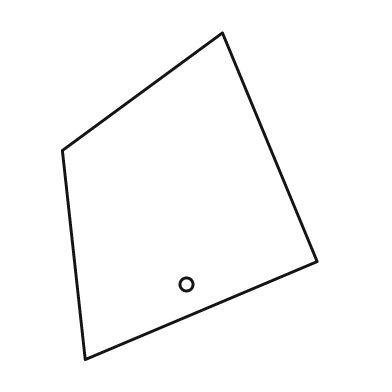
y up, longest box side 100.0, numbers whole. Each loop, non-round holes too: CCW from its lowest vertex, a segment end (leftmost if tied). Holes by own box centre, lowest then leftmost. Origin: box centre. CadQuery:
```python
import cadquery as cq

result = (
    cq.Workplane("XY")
    .moveTo(-32.0, -50.0)
    .lineTo(39.0, -20.0)
    .lineTo(10.0, 50.0)
    .lineTo(-39.0, 14.0)
    .close()
    .moveTo(-1.0, -27.0)
    .circle(2.0)
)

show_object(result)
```